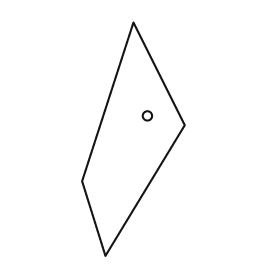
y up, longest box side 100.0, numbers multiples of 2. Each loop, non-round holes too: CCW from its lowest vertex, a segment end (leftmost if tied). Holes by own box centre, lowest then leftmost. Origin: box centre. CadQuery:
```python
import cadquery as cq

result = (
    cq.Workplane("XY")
    .moveTo(-12.0, -50.0)
    .lineTo(22.0, 6.0)
    .lineTo(0.0, 50.0)
    .lineTo(-22.0, -18.0)
    .close()
    .moveTo(6.0, 10.0)
    .circle(2.0)
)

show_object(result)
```